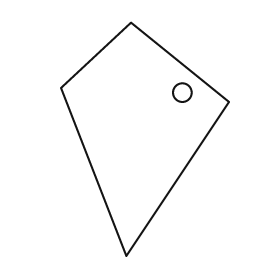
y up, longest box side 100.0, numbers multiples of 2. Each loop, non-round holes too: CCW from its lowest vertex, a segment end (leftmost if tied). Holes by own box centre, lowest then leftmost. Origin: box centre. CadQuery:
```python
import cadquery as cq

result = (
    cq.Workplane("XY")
    .moveTo(-8.0, -50.0)
    .lineTo(36.0, 16.0)
    .lineTo(-6.0, 50.0)
    .lineTo(-36.0, 22.0)
    .close()
    .moveTo(16.0, 20.0)
    .circle(4.0)
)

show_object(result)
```